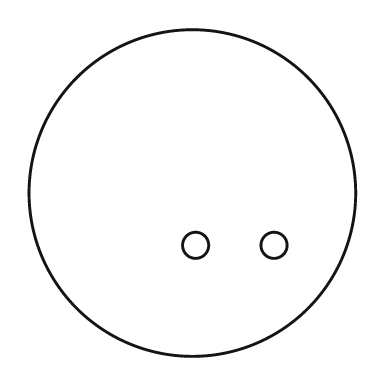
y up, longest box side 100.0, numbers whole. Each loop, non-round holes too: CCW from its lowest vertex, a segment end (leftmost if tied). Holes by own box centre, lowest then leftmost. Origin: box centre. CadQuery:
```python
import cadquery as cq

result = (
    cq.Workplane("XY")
    .moveTo(0.0, 0.0)
    .circle(50.0)
    .moveTo(1.0, -16.0)
    .circle(4.0)
    .moveTo(25.0, -16.0)
    .circle(4.0)
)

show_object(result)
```